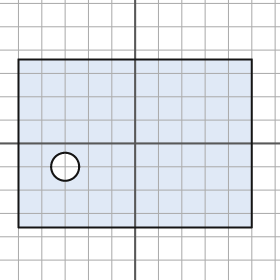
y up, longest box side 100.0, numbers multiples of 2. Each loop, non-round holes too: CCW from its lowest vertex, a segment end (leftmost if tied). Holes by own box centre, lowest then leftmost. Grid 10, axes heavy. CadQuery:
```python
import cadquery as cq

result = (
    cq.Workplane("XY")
    .moveTo(-50.0, -36.0)
    .lineTo(50.0, -36.0)
    .lineTo(50.0, 36.0)
    .lineTo(-50.0, 36.0)
    .close()
    .moveTo(-30.0, -10.0)
    .circle(6.0)
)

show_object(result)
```